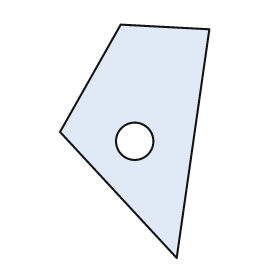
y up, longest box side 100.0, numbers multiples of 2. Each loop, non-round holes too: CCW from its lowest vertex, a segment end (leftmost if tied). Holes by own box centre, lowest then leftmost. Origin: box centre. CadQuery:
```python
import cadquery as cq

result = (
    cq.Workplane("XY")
    .moveTo(18.0, -50.0)
    .lineTo(32.0, 48.0)
    .lineTo(-6.0, 50.0)
    .lineTo(-32.0, 4.0)
    .close()
    .moveTo(0.0, 0.0)
    .circle(8.0)
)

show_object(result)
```